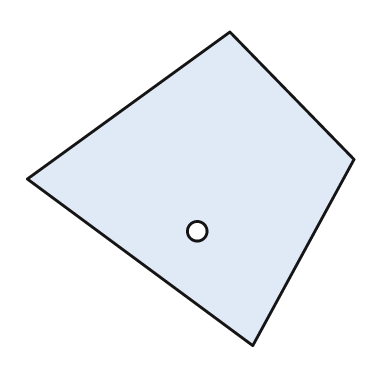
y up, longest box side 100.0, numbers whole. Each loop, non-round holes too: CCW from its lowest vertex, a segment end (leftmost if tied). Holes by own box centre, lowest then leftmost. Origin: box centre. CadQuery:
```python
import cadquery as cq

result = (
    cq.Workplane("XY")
    .moveTo(19.0, -48.0)
    .lineTo(50.0, 9.0)
    .lineTo(12.0, 48.0)
    .lineTo(-50.0, 3.0)
    .close()
    .moveTo(2.0, -13.0)
    .circle(3.0)
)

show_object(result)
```